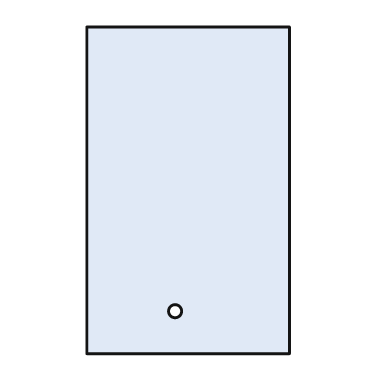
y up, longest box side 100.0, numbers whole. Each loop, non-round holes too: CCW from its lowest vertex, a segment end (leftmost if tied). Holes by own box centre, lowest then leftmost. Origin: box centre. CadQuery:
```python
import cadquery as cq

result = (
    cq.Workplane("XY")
    .moveTo(-31.0, -50.0)
    .lineTo(31.0, -50.0)
    .lineTo(31.0, 50.0)
    .lineTo(-31.0, 50.0)
    .close()
    .moveTo(-4.0, -37.0)
    .circle(2.0)
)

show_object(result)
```